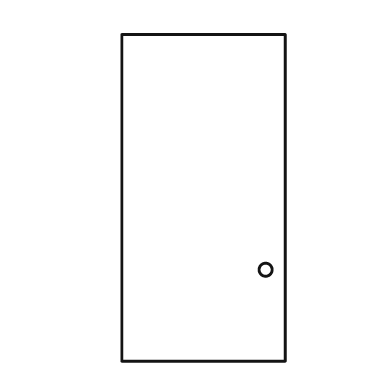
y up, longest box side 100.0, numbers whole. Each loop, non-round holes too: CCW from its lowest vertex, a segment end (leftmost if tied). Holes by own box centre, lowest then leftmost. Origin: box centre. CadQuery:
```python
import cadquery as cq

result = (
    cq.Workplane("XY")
    .moveTo(-25.0, -50.0)
    .lineTo(25.0, -50.0)
    .lineTo(25.0, 50.0)
    .lineTo(-25.0, 50.0)
    .close()
    .moveTo(19.0, -22.0)
    .circle(2.0)
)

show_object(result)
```